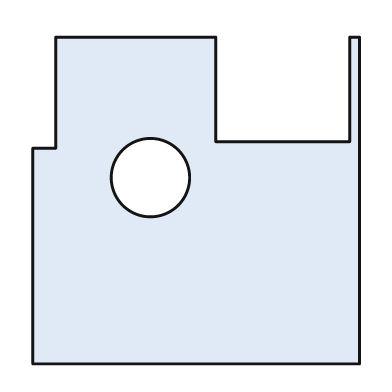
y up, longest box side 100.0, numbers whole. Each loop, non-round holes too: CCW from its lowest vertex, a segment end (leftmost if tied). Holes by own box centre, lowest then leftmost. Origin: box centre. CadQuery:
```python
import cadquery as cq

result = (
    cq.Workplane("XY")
    .moveTo(-50.0, -50.0)
    .lineTo(50.0, -50.0)
    .lineTo(50.0, 50.0)
    .lineTo(47.0, 50.0)
    .lineTo(47.0, 18.0)
    .lineTo(6.0, 18.0)
    .lineTo(6.0, 50.0)
    .lineTo(-43.0, 50.0)
    .lineTo(-43.0, 16.0)
    .lineTo(-50.0, 16.0)
    .close()
    .moveTo(-14.0, 7.0)
    .circle(12.0)
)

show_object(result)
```